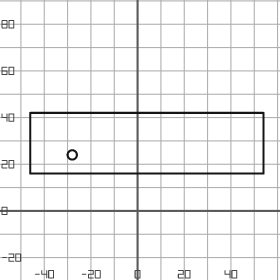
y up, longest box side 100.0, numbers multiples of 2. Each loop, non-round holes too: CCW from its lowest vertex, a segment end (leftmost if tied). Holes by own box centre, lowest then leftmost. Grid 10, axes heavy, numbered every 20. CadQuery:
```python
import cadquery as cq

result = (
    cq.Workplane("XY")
    .moveTo(-46.0, 16.0)
    .lineTo(54.0, 16.0)
    .lineTo(54.0, 42.0)
    .lineTo(-46.0, 42.0)
    .close()
    .moveTo(-28.0, 24.0)
    .circle(2.0)
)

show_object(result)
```